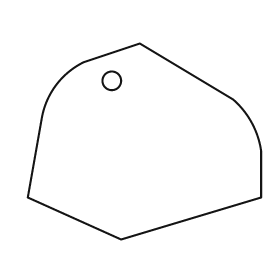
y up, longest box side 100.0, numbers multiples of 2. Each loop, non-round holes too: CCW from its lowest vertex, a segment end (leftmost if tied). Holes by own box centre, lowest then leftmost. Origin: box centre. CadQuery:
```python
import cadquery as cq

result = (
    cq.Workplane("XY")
    .moveTo(-10.0, -42.0)
    .lineTo(50.0, -24.0)
    .lineTo(50.0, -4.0)
    .threePointArc((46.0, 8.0), (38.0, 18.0))
    .lineTo(-2.0, 42.0)
    .lineTo(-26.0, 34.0)
    .threePointArc((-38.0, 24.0), (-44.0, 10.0))
    .lineTo(-50.0, -24.0)
    .close()
    .moveTo(-14.0, 26.0)
    .circle(4.0)
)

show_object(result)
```